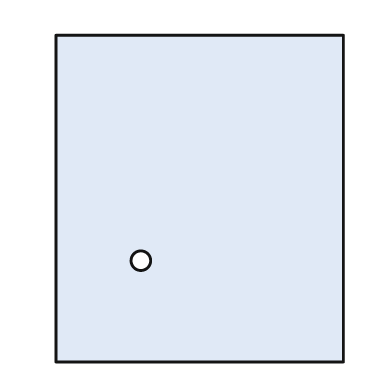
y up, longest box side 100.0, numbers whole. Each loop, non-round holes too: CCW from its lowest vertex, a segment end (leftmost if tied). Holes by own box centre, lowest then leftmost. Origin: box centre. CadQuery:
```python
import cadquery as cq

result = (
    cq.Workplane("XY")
    .moveTo(-44.0, -50.0)
    .lineTo(44.0, -50.0)
    .lineTo(44.0, 50.0)
    .lineTo(-44.0, 50.0)
    .close()
    .moveTo(-18.0, -19.0)
    .circle(3.0)
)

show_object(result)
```